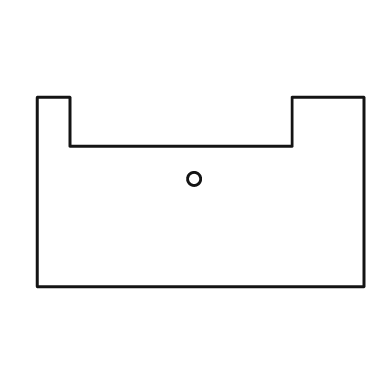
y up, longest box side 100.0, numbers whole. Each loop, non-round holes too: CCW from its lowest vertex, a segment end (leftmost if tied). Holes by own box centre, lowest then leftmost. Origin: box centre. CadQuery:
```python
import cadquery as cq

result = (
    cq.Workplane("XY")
    .moveTo(-50.0, -29.0)
    .lineTo(50.0, -29.0)
    .lineTo(50.0, 29.0)
    .lineTo(28.0, 29.0)
    .lineTo(28.0, 14.0)
    .lineTo(-40.0, 14.0)
    .lineTo(-40.0, 29.0)
    .lineTo(-50.0, 29.0)
    .close()
    .moveTo(-2.0, 4.0)
    .circle(2.0)
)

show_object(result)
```